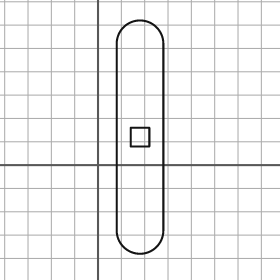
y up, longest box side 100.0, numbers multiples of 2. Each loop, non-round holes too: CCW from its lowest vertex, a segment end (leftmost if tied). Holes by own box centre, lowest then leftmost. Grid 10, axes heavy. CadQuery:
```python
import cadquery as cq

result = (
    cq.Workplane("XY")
    .moveTo(8.0, -28.0)
    .threePointArc((18.0, -38.0), (28.0, -28.0))
    .lineTo(28.0, 52.0)
    .threePointArc((18.0, 62.0), (8.0, 52.0))
    .close()
    .moveTo(14.0, 8.0)
    .lineTo(22.0, 8.0)
    .lineTo(22.0, 16.0)
    .lineTo(14.0, 16.0)
    .close()
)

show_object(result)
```